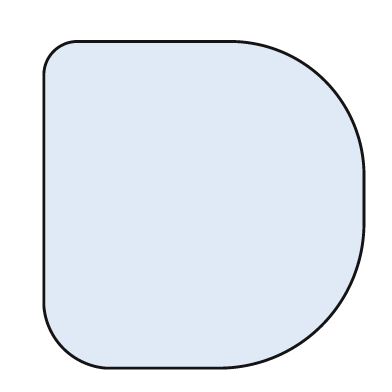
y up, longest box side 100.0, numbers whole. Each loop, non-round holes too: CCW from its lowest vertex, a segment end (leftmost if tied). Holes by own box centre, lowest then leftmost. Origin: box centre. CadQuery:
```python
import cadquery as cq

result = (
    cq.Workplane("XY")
    .moveTo(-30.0, -50.0)
    .lineTo(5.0, -50.0)
    .threePointArc((36.0, -37.0), (49.0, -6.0))
    .lineTo(49.0, 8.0)
    .threePointArc((37.0, 38.0), (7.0, 50.0))
    .lineTo(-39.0, 50.0)
    .threePointArc((-46.0, 47.0), (-49.0, 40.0))
    .lineTo(-49.0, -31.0)
    .threePointArc((-43.0, -44.0), (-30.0, -50.0))
    .close()
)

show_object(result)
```